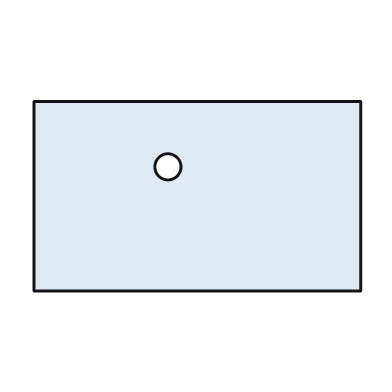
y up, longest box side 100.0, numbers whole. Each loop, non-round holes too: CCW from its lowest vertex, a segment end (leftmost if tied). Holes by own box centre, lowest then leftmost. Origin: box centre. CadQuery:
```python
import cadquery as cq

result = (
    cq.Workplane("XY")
    .moveTo(-50.0, -29.0)
    .lineTo(50.0, -29.0)
    .lineTo(50.0, 29.0)
    .lineTo(-50.0, 29.0)
    .close()
    .moveTo(-9.0, 9.0)
    .circle(4.0)
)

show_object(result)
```